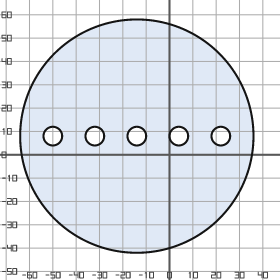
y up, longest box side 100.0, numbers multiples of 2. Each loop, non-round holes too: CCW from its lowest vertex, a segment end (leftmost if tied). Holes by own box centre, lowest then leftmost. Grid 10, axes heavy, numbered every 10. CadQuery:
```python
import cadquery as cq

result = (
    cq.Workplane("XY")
    .moveTo(-14.0, 8.0)
    .circle(50.0)
    .moveTo(-50.0, 8.0)
    .circle(4.0)
    .moveTo(-32.0, 8.0)
    .circle(4.0)
    .moveTo(-14.0, 8.0)
    .circle(4.0)
    .moveTo(4.0, 8.0)
    .circle(4.0)
    .moveTo(22.0, 8.0)
    .circle(4.0)
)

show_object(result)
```